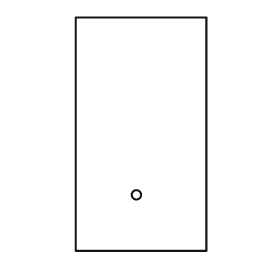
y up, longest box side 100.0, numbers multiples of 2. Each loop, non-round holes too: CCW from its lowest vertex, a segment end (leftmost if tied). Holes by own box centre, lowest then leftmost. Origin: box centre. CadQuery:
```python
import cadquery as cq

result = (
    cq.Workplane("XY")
    .moveTo(-28.0, -50.0)
    .lineTo(28.0, -50.0)
    .lineTo(28.0, 50.0)
    .lineTo(-28.0, 50.0)
    .close()
    .moveTo(-2.0, -26.0)
    .circle(2.0)
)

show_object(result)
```